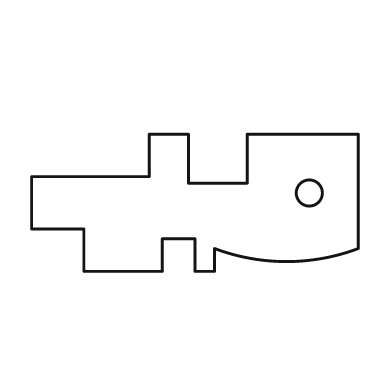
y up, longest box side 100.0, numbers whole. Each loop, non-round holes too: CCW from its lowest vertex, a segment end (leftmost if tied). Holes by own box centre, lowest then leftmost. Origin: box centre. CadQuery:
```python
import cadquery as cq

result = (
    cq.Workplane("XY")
    .moveTo(-34.0, -21.0)
    .lineTo(-10.0, -21.0)
    .lineTo(-10.0, -11.0)
    .lineTo(0.0, -11.0)
    .lineTo(0.0, -21.0)
    .lineTo(6.0, -21.0)
    .lineTo(6.0, -14.0)
    .threePointArc((28.0, -18.0), (50.0, -14.0))
    .lineTo(50.0, 21.0)
    .lineTo(16.0, 21.0)
    .lineTo(16.0, 6.0)
    .lineTo(-2.0, 6.0)
    .lineTo(-2.0, 21.0)
    .lineTo(-14.0, 21.0)
    .lineTo(-14.0, 8.0)
    .lineTo(-50.0, 8.0)
    .lineTo(-50.0, -8.0)
    .lineTo(-34.0, -8.0)
    .close()
    .moveTo(35.0, 3.0)
    .circle(4.0)
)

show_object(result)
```